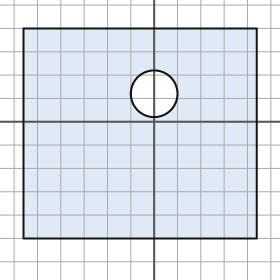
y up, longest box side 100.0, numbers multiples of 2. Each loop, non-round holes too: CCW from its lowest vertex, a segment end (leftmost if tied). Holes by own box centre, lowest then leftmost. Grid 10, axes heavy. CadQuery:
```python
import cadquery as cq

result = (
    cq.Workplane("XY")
    .moveTo(-56.0, -50.0)
    .lineTo(44.0, -50.0)
    .lineTo(44.0, 40.0)
    .lineTo(-56.0, 40.0)
    .close()
    .moveTo(0.0, 12.0)
    .circle(10.0)
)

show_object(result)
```